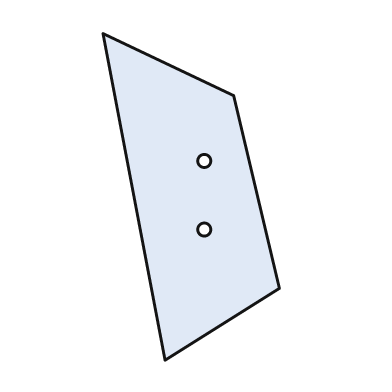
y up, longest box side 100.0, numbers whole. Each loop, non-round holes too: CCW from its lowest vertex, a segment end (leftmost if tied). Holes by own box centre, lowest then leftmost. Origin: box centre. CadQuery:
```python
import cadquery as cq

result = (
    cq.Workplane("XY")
    .moveTo(-8.0, -50.0)
    .lineTo(27.0, -28.0)
    .lineTo(13.0, 31.0)
    .lineTo(-27.0, 50.0)
    .close()
    .moveTo(4.0, -10.0)
    .circle(2.0)
    .moveTo(4.0, 11.0)
    .circle(2.0)
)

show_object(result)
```